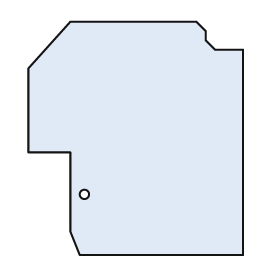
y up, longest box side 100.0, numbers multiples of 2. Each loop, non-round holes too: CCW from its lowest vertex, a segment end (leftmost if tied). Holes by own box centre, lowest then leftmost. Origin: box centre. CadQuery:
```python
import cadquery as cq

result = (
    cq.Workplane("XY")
    .moveTo(-24.0, -50.0)
    .lineTo(46.0, -50.0)
    .lineTo(46.0, 38.0)
    .lineTo(34.0, 38.0)
    .lineTo(30.0, 42.0)
    .lineTo(30.0, 46.0)
    .lineTo(26.0, 50.0)
    .lineTo(-28.0, 50.0)
    .lineTo(-46.0, 30.0)
    .lineTo(-46.0, -6.0)
    .lineTo(-28.0, -6.0)
    .lineTo(-28.0, -40.0)
    .close()
    .moveTo(-22.0, -24.0)
    .circle(2.0)
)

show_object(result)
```